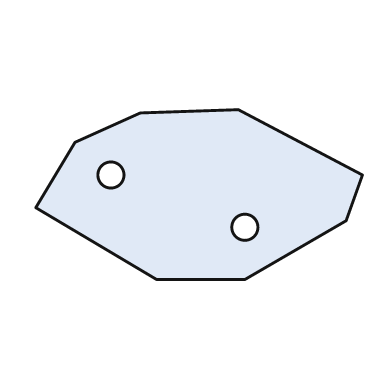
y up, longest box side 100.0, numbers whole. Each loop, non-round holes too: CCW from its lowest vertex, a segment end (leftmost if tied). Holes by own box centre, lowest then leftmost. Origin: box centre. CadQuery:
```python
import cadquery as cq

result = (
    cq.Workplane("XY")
    .moveTo(-13.0, -26.0)
    .lineTo(14.0, -26.0)
    .lineTo(45.0, -8.0)
    .lineTo(50.0, 6.0)
    .lineTo(12.0, 26.0)
    .lineTo(-18.0, 25.0)
    .lineTo(-38.0, 16.0)
    .lineTo(-50.0, -4.0)
    .close()
    .moveTo(14.0, -10.0)
    .circle(4.0)
    .moveTo(-27.0, 6.0)
    .circle(4.0)
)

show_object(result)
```